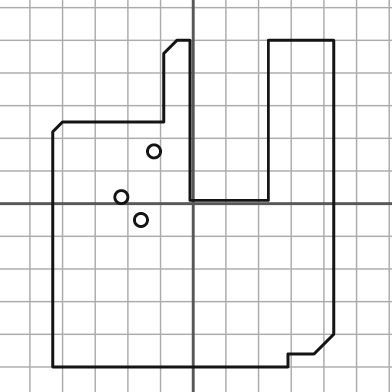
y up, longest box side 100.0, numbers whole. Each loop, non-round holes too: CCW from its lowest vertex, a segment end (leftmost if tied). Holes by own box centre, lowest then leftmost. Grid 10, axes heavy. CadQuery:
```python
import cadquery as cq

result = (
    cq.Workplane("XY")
    .moveTo(-43.0, -50.0)
    .lineTo(29.0, -50.0)
    .lineTo(29.0, -46.0)
    .lineTo(37.0, -46.0)
    .lineTo(43.0, -40.0)
    .lineTo(43.0, 50.0)
    .lineTo(23.0, 50.0)
    .lineTo(23.0, 1.0)
    .lineTo(-1.0, 1.0)
    .lineTo(-1.0, 50.0)
    .lineTo(-5.0, 50.0)
    .lineTo(-9.0, 46.0)
    .lineTo(-9.0, 25.0)
    .lineTo(-40.0, 25.0)
    .lineTo(-43.0, 22.0)
    .close()
    .moveTo(-16.0, -5.0)
    .circle(2.0)
    .moveTo(-22.0, 2.0)
    .circle(2.0)
    .moveTo(-12.0, 16.0)
    .circle(2.0)
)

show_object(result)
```